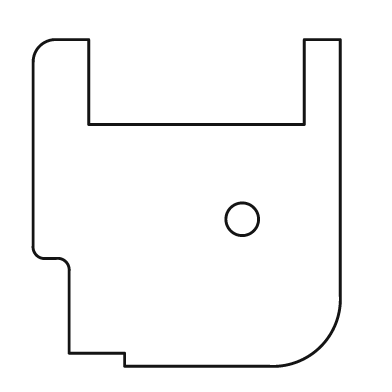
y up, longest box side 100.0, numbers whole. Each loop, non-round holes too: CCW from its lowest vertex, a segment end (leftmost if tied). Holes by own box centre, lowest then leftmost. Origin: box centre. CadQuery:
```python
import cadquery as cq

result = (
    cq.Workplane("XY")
    .moveTo(-19.0, -50.0)
    .lineTo(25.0, -50.0)
    .threePointArc((41.0, -44.0), (47.0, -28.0))
    .lineTo(47.0, 50.0)
    .lineTo(36.0, 50.0)
    .lineTo(36.0, 24.0)
    .lineTo(-30.0, 24.0)
    .lineTo(-30.0, 50.0)
    .lineTo(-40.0, 50.0)
    .threePointArc((-45.0, 48.0), (-47.0, 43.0))
    .lineTo(-47.0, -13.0)
    .threePointArc((-46.0, -16.0), (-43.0, -17.0))
    .lineTo(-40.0, -17.0)
    .threePointArc((-37.0, -18.0), (-36.0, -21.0))
    .lineTo(-36.0, -46.0)
    .lineTo(-19.0, -46.0)
    .close()
    .moveTo(17.0, -5.0)
    .circle(5.0)
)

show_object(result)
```